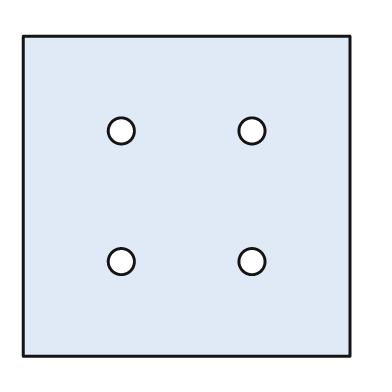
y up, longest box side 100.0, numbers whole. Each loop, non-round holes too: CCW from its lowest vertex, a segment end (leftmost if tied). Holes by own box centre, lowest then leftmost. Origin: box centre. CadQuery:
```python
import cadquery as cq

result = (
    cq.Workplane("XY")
    .moveTo(-50.0, -49.0)
    .lineTo(50.0, -49.0)
    .lineTo(50.0, 49.0)
    .lineTo(-50.0, 49.0)
    .close()
    .moveTo(-20.0, -20.0)
    .circle(4.0)
    .moveTo(20.0, -20.0)
    .circle(4.0)
    .moveTo(-20.0, 20.0)
    .circle(4.0)
    .moveTo(20.0, 20.0)
    .circle(4.0)
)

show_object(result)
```